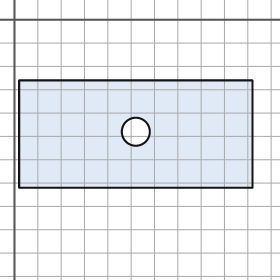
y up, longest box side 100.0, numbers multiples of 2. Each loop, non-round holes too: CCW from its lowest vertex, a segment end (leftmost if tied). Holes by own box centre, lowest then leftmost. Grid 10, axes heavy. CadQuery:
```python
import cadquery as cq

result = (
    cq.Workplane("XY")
    .moveTo(2.0, -72.0)
    .lineTo(102.0, -72.0)
    .lineTo(102.0, -26.0)
    .lineTo(2.0, -26.0)
    .close()
    .moveTo(52.0, -48.0)
    .circle(6.0)
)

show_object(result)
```